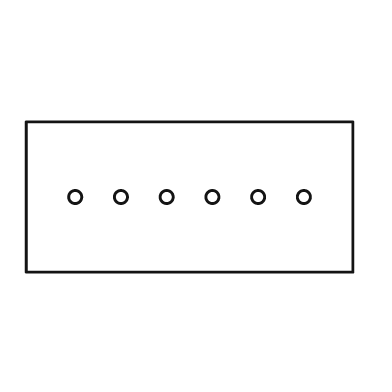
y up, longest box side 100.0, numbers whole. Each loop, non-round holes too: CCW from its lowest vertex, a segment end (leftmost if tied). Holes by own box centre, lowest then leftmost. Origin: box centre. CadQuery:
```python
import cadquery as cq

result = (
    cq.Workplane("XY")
    .moveTo(-50.0, -23.0)
    .lineTo(50.0, -23.0)
    .lineTo(50.0, 23.0)
    .lineTo(-50.0, 23.0)
    .close()
    .moveTo(-35.0, 0.0)
    .circle(2.0)
    .moveTo(-21.0, 0.0)
    .circle(2.0)
    .moveTo(-7.0, 0.0)
    .circle(2.0)
    .moveTo(7.0, 0.0)
    .circle(2.0)
    .moveTo(21.0, 0.0)
    .circle(2.0)
    .moveTo(35.0, 0.0)
    .circle(2.0)
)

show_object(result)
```